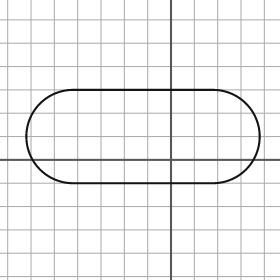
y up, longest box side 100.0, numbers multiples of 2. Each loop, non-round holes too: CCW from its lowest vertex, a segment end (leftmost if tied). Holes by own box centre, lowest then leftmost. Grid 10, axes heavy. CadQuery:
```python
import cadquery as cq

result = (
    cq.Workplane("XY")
    .moveTo(-42.0, -10.0)
    .lineTo(18.0, -10.0)
    .threePointArc((38.0, 10.0), (18.0, 30.0))
    .lineTo(-42.0, 30.0)
    .threePointArc((-62.0, 10.0), (-42.0, -10.0))
    .close()
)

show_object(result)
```